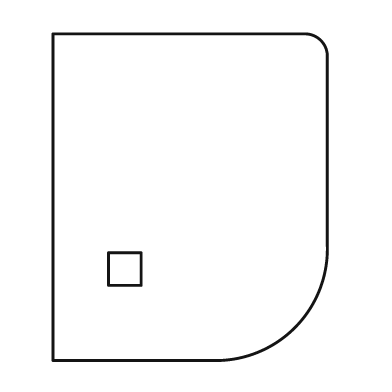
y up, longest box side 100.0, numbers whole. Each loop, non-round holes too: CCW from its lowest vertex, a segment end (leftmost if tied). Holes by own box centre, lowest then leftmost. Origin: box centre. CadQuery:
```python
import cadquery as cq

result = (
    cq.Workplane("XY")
    .moveTo(-42.0, -50.0)
    .lineTo(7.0, -50.0)
    .threePointArc((32.0, -40.0), (42.0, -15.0))
    .lineTo(42.0, 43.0)
    .threePointArc((40.0, 48.0), (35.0, 50.0))
    .lineTo(-42.0, 50.0)
    .close()
    .moveTo(-25.0, -27.0)
    .lineTo(-15.0, -27.0)
    .lineTo(-15.0, -17.0)
    .lineTo(-25.0, -17.0)
    .close()
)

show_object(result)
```